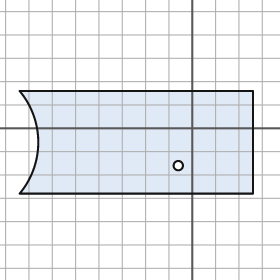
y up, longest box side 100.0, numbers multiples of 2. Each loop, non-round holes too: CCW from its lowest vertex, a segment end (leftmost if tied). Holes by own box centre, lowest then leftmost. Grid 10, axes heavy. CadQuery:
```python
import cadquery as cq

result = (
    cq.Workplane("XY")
    .moveTo(-74.0, -28.0)
    .lineTo(26.0, -28.0)
    .lineTo(26.0, 16.0)
    .lineTo(-74.0, 16.0)
    .threePointArc((-66.0, -6.0), (-74.0, -28.0))
    .close()
    .moveTo(-6.0, -16.0)
    .circle(2.0)
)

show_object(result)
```